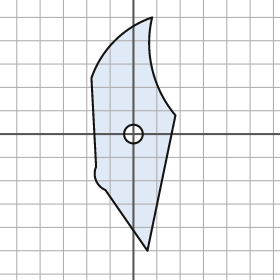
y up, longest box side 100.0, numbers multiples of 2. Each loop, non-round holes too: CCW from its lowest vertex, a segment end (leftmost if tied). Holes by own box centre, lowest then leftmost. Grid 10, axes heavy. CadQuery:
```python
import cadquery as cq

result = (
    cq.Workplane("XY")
    .moveTo(6.0, -50.0)
    .lineTo(18.0, 8.0)
    .threePointArc((8.0, 28.0), (8.0, 50.0))
    .threePointArc((-8.0, 40.0), (-18.0, 24.0))
    .lineTo(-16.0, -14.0)
    .threePointArc((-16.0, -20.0), (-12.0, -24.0))
    .close()
    .moveTo(0.0, 0.0)
    .circle(4.0)
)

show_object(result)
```